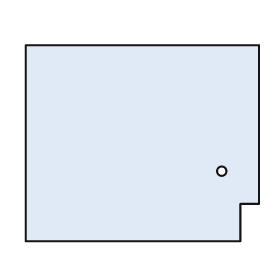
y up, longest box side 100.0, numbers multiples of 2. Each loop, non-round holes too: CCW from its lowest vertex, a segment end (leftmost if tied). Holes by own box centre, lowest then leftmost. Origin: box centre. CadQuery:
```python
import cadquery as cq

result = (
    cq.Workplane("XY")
    .moveTo(-50.0, -42.0)
    .lineTo(42.0, -42.0)
    .lineTo(42.0, -26.0)
    .lineTo(50.0, -26.0)
    .lineTo(50.0, 42.0)
    .lineTo(-50.0, 42.0)
    .close()
    .moveTo(34.0, -12.0)
    .circle(2.0)
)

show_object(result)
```